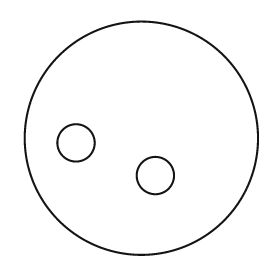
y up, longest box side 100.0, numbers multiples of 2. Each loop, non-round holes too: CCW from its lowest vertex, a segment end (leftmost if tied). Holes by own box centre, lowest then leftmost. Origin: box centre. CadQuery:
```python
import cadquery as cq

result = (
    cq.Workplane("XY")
    .moveTo(0.0, 0.0)
    .circle(50.0)
    .moveTo(6.0, -16.0)
    .circle(8.0)
    .moveTo(-28.0, -2.0)
    .circle(8.0)
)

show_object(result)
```